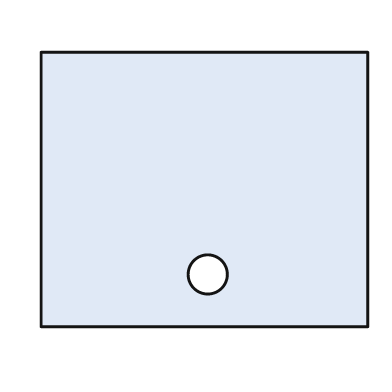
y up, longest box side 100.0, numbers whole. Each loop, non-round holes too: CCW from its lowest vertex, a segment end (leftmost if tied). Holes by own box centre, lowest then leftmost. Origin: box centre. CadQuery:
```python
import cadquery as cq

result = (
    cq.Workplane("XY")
    .moveTo(-50.0, -42.0)
    .lineTo(50.0, -42.0)
    .lineTo(50.0, 42.0)
    .lineTo(-50.0, 42.0)
    .close()
    .moveTo(1.0, -26.0)
    .circle(6.0)
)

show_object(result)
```